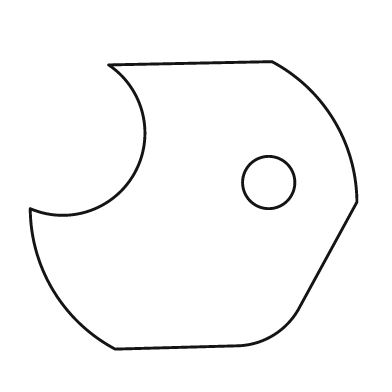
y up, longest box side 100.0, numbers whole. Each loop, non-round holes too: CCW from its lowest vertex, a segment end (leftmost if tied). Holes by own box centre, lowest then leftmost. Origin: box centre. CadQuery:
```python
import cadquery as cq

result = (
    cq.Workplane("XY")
    .moveTo(-24.0, -44.0)
    .lineTo(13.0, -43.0)
    .threePointArc((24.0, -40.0), (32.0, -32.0))
    .lineTo(50.0, 1.0)
    .threePointArc((43.0, 26.0), (24.0, 44.0))
    .lineTo(-26.0, 43.0)
    .threePointArc((-18.0, 10.0), (-50.0, -1.0))
    .threePointArc((-43.0, -26.0), (-24.0, -44.0))
    .close()
    .moveTo(23.0, 7.0)
    .circle(8.0)
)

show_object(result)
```